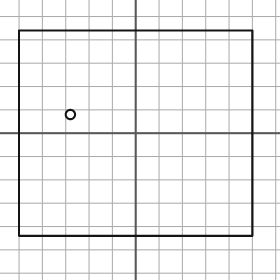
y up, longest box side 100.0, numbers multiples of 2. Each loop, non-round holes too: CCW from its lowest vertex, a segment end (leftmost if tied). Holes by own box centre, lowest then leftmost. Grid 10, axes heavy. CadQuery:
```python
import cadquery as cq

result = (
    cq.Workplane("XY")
    .moveTo(-50.0, -44.0)
    .lineTo(50.0, -44.0)
    .lineTo(50.0, 44.0)
    .lineTo(-50.0, 44.0)
    .close()
    .moveTo(-28.0, 8.0)
    .circle(2.0)
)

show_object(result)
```